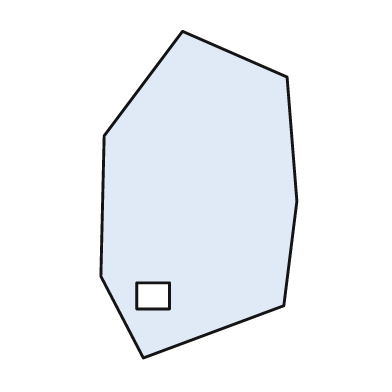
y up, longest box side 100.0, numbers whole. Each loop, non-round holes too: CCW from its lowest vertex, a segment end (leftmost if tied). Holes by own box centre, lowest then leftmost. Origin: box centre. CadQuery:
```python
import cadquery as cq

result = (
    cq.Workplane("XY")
    .moveTo(-17.0, -50.0)
    .lineTo(26.0, -34.0)
    .lineTo(30.0, -2.0)
    .lineTo(27.0, 36.0)
    .lineTo(-5.0, 50.0)
    .lineTo(-29.0, 18.0)
    .lineTo(-30.0, -25.0)
    .close()
    .moveTo(-19.0, -35.0)
    .lineTo(-9.0, -35.0)
    .lineTo(-9.0, -27.0)
    .lineTo(-19.0, -27.0)
    .close()
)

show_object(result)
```